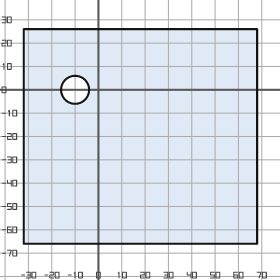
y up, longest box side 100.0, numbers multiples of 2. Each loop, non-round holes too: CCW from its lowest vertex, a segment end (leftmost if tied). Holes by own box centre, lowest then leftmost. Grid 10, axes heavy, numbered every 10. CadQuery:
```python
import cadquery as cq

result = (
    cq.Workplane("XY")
    .moveTo(-32.0, -66.0)
    .lineTo(68.0, -66.0)
    .lineTo(68.0, 26.0)
    .lineTo(-32.0, 26.0)
    .close()
    .moveTo(-10.0, 0.0)
    .circle(6.0)
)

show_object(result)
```